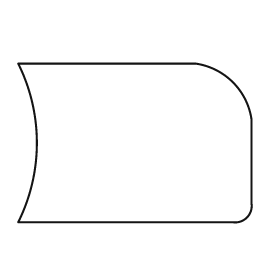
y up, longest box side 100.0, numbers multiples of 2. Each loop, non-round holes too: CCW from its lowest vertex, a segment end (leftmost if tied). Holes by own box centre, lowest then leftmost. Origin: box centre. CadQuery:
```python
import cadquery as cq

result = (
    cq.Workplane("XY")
    .moveTo(-50.0, -34.0)
    .lineTo(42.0, -34.0)
    .threePointArc((48.0, -32.0), (50.0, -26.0))
    .lineTo(50.0, 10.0)
    .threePointArc((42.0, 26.0), (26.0, 34.0))
    .lineTo(-50.0, 34.0)
    .threePointArc((-42.0, 0.0), (-50.0, -34.0))
    .close()
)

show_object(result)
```